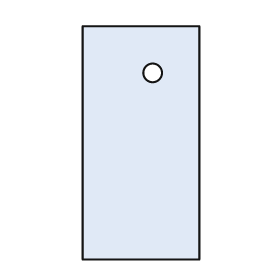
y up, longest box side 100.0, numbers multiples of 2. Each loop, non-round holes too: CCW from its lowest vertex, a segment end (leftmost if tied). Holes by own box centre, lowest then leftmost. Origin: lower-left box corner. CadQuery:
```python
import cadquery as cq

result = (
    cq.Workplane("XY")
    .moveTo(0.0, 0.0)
    .lineTo(50.0, 0.0)
    .lineTo(50.0, 100.0)
    .lineTo(0.0, 100.0)
    .close()
    .moveTo(30.0, 80.0)
    .circle(4.0)
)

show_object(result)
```